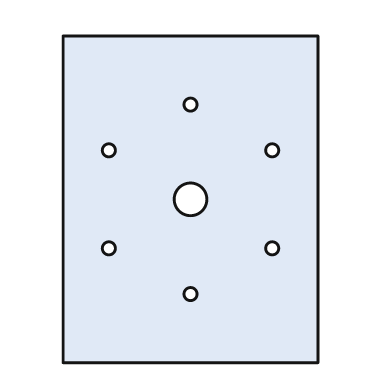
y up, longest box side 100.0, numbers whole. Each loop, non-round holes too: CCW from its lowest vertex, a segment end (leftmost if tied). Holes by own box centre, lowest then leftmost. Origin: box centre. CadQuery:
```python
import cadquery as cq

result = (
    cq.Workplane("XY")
    .moveTo(-39.0, -50.0)
    .lineTo(39.0, -50.0)
    .lineTo(39.0, 50.0)
    .lineTo(-39.0, 50.0)
    .close()
    .moveTo(0.0, -29.0)
    .circle(2.0)
    .moveTo(-25.0, -15.0)
    .circle(2.0)
    .moveTo(25.0, -15.0)
    .circle(2.0)
    .moveTo(0.0, 0.0)
    .circle(5.0)
    .moveTo(-25.0, 15.0)
    .circle(2.0)
    .moveTo(25.0, 15.0)
    .circle(2.0)
    .moveTo(0.0, 29.0)
    .circle(2.0)
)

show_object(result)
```